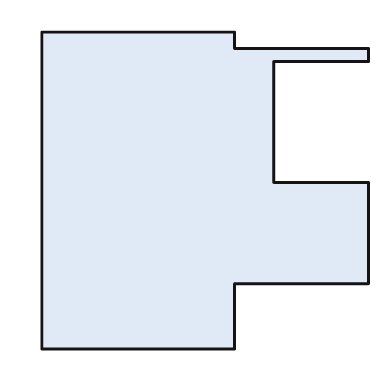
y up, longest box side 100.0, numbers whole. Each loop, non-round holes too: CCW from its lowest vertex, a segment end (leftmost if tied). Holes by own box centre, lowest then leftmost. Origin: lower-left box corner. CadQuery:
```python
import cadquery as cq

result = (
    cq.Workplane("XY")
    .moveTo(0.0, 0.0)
    .lineTo(59.0, 0.0)
    .lineTo(59.0, 20.0)
    .lineTo(100.0, 20.0)
    .lineTo(100.0, 51.0)
    .lineTo(71.0, 51.0)
    .lineTo(71.0, 88.0)
    .lineTo(100.0, 88.0)
    .lineTo(100.0, 92.0)
    .lineTo(59.0, 92.0)
    .lineTo(59.0, 97.0)
    .lineTo(0.0, 97.0)
    .close()
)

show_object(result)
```